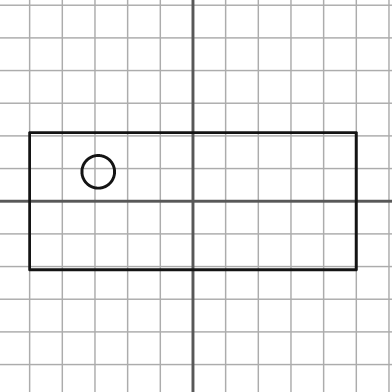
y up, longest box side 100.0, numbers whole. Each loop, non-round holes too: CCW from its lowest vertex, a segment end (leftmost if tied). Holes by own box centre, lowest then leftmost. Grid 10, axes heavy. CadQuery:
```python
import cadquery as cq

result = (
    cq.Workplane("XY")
    .moveTo(-50.0, -21.0)
    .lineTo(50.0, -21.0)
    .lineTo(50.0, 21.0)
    .lineTo(-50.0, 21.0)
    .close()
    .moveTo(-29.0, 9.0)
    .circle(5.0)
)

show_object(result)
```